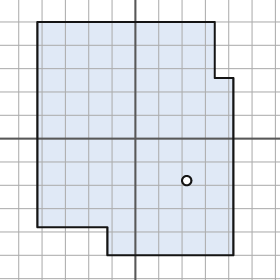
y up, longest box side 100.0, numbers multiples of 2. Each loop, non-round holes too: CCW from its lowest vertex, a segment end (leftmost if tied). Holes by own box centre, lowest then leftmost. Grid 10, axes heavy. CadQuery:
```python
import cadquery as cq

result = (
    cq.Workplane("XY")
    .moveTo(-12.0, -50.0)
    .lineTo(42.0, -50.0)
    .lineTo(42.0, 26.0)
    .lineTo(34.0, 26.0)
    .lineTo(34.0, 50.0)
    .lineTo(-42.0, 50.0)
    .lineTo(-42.0, -38.0)
    .lineTo(-12.0, -38.0)
    .close()
    .moveTo(22.0, -18.0)
    .circle(2.0)
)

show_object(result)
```